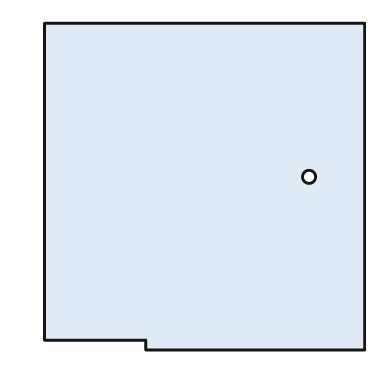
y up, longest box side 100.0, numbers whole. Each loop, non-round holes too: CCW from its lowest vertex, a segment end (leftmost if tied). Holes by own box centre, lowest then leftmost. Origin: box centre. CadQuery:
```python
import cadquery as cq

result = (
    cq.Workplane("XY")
    .moveTo(-18.0, -50.0)
    .lineTo(49.0, -50.0)
    .lineTo(49.0, 50.0)
    .lineTo(-49.0, 50.0)
    .lineTo(-49.0, -47.0)
    .lineTo(-18.0, -47.0)
    .close()
    .moveTo(32.0, 3.0)
    .circle(2.0)
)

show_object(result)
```